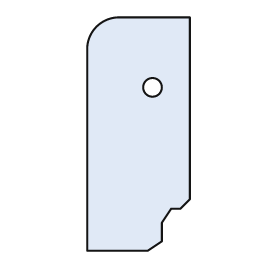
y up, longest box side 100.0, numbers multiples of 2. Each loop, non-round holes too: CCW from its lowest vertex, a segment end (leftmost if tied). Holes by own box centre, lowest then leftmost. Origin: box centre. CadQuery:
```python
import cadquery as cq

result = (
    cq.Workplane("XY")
    .moveTo(-22.0, -50.0)
    .lineTo(4.0, -50.0)
    .lineTo(10.0, -46.0)
    .lineTo(10.0, -38.0)
    .lineTo(14.0, -32.0)
    .lineTo(18.0, -32.0)
    .lineTo(22.0, -28.0)
    .lineTo(22.0, 50.0)
    .lineTo(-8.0, 50.0)
    .threePointArc((-18.0, 46.0), (-22.0, 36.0))
    .close()
    .moveTo(6.0, 20.0)
    .circle(4.0)
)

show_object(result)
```